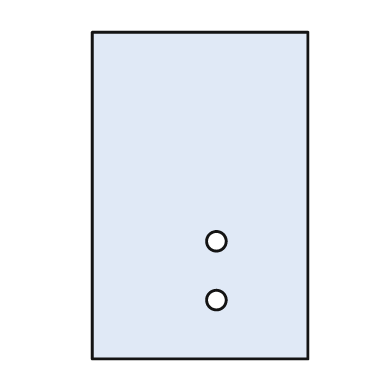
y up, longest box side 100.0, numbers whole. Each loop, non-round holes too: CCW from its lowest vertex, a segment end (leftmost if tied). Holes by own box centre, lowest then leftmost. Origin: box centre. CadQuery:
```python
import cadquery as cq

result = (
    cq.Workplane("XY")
    .moveTo(-33.0, -50.0)
    .lineTo(33.0, -50.0)
    .lineTo(33.0, 50.0)
    .lineTo(-33.0, 50.0)
    .close()
    .moveTo(5.0, -32.0)
    .circle(3.0)
    .moveTo(5.0, -14.0)
    .circle(3.0)
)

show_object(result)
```